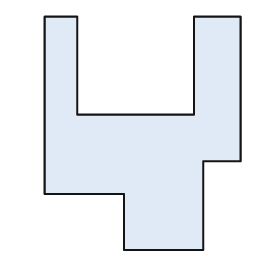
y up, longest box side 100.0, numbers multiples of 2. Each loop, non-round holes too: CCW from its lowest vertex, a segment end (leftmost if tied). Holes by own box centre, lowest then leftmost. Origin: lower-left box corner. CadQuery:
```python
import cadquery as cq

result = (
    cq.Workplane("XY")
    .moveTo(34.0, 0.0)
    .lineTo(68.0, 0.0)
    .lineTo(68.0, 38.0)
    .lineTo(84.0, 38.0)
    .lineTo(84.0, 100.0)
    .lineTo(64.0, 100.0)
    .lineTo(64.0, 58.0)
    .lineTo(14.0, 58.0)
    .lineTo(14.0, 100.0)
    .lineTo(0.0, 100.0)
    .lineTo(0.0, 24.0)
    .lineTo(34.0, 24.0)
    .close()
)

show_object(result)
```